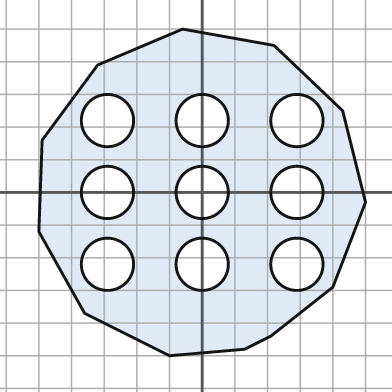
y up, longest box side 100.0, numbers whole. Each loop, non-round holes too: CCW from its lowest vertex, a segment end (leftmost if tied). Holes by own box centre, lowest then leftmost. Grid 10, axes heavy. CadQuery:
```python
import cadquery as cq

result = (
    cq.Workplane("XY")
    .moveTo(-10.0, -50.0)
    .lineTo(13.0, -48.0)
    .lineTo(21.0, -44.0)
    .lineTo(40.0, -29.0)
    .lineTo(50.0, -3.0)
    .lineTo(43.0, 25.0)
    .lineTo(22.0, 45.0)
    .lineTo(-6.0, 50.0)
    .lineTo(-32.0, 39.0)
    .lineTo(-49.0, 16.0)
    .lineTo(-50.0, -12.0)
    .lineTo(-36.0, -37.0)
    .close()
    .moveTo(-29.0, -22.0)
    .circle(8.0)
    .moveTo(0.0, -22.0)
    .circle(8.0)
    .moveTo(29.0, -22.0)
    .circle(8.0)
    .moveTo(-29.0, 0.0)
    .circle(8.0)
    .moveTo(0.0, 0.0)
    .circle(8.0)
    .moveTo(29.0, 0.0)
    .circle(8.0)
    .moveTo(-29.0, 22.0)
    .circle(8.0)
    .moveTo(0.0, 22.0)
    .circle(8.0)
    .moveTo(29.0, 22.0)
    .circle(8.0)
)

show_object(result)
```